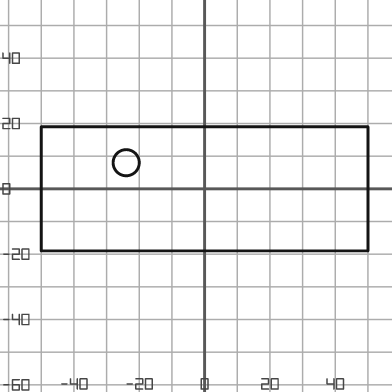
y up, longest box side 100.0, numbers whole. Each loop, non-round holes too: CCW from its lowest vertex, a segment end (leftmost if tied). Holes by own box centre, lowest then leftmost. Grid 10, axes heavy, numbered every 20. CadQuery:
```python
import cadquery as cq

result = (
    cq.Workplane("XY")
    .moveTo(-50.0, -19.0)
    .lineTo(50.0, -19.0)
    .lineTo(50.0, 19.0)
    .lineTo(-50.0, 19.0)
    .close()
    .moveTo(-24.0, 8.0)
    .circle(4.0)
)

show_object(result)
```